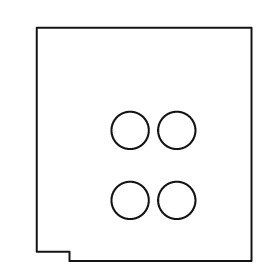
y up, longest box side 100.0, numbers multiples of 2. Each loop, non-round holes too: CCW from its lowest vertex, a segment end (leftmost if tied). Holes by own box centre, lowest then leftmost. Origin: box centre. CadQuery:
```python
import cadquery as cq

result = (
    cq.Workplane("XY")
    .moveTo(-32.0, -50.0)
    .lineTo(46.0, -50.0)
    .lineTo(46.0, 50.0)
    .lineTo(-46.0, 50.0)
    .lineTo(-46.0, -46.0)
    .lineTo(-32.0, -46.0)
    .close()
    .moveTo(-6.0, -24.0)
    .circle(8.0)
    .moveTo(14.0, -24.0)
    .circle(8.0)
    .moveTo(-6.0, 6.0)
    .circle(8.0)
    .moveTo(14.0, 6.0)
    .circle(8.0)
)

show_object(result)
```